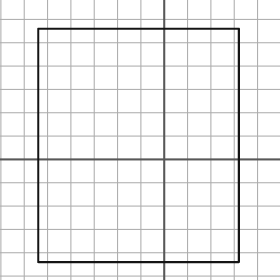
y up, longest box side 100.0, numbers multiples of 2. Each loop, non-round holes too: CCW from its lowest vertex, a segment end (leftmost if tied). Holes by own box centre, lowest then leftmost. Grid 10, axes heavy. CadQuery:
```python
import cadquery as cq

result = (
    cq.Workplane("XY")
    .moveTo(-54.0, -44.0)
    .lineTo(32.0, -44.0)
    .lineTo(32.0, 56.0)
    .lineTo(-54.0, 56.0)
    .close()
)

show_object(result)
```